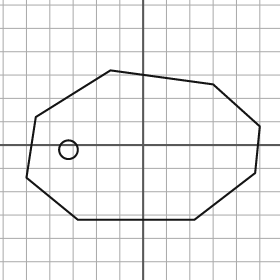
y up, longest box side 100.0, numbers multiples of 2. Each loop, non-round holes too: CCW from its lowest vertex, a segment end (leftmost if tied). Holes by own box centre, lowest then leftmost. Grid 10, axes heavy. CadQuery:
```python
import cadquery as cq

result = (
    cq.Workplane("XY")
    .moveTo(-28.0, -32.0)
    .lineTo(22.0, -32.0)
    .lineTo(48.0, -12.0)
    .lineTo(50.0, 8.0)
    .lineTo(30.0, 26.0)
    .lineTo(-14.0, 32.0)
    .lineTo(-46.0, 12.0)
    .lineTo(-50.0, -14.0)
    .close()
    .moveTo(-32.0, -2.0)
    .circle(4.0)
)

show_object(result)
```